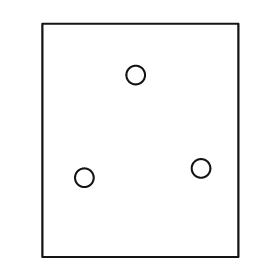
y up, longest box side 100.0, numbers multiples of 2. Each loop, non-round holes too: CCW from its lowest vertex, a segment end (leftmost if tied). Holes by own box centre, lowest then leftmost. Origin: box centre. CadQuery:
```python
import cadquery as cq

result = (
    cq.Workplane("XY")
    .moveTo(-42.0, -50.0)
    .lineTo(42.0, -50.0)
    .lineTo(42.0, 50.0)
    .lineTo(-42.0, 50.0)
    .close()
    .moveTo(-24.0, -16.0)
    .circle(4.0)
    .moveTo(26.0, -12.0)
    .circle(4.0)
    .moveTo(-2.0, 28.0)
    .circle(4.0)
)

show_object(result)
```